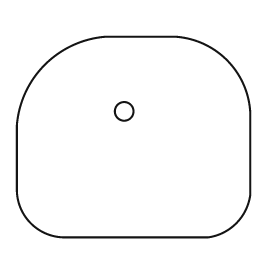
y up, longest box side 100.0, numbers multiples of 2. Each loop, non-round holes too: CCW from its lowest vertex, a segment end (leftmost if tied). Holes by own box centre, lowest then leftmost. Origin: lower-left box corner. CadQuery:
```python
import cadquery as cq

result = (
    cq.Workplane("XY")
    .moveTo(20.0, 0.0)
    .lineTo(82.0, 0.0)
    .threePointArc((94.0, 6.0), (100.0, 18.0))
    .lineTo(100.0, 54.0)
    .threePointArc((90.0, 76.0), (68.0, 86.0))
    .lineTo(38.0, 86.0)
    .threePointArc((12.0, 74.0), (0.0, 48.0))
    .lineTo(0.0, 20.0)
    .threePointArc((6.0, 6.0), (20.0, 0.0))
    .close()
    .moveTo(46.0, 54.0)
    .circle(4.0)
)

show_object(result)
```